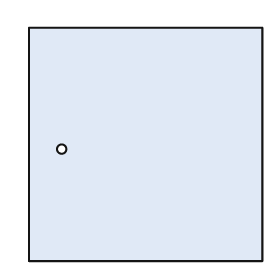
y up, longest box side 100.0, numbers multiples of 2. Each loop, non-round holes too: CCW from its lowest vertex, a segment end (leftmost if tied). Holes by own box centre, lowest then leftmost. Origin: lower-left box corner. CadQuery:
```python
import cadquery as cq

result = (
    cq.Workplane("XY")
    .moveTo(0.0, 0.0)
    .lineTo(100.0, 0.0)
    .lineTo(100.0, 100.0)
    .lineTo(0.0, 100.0)
    .close()
    .moveTo(14.0, 48.0)
    .circle(2.0)
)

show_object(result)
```